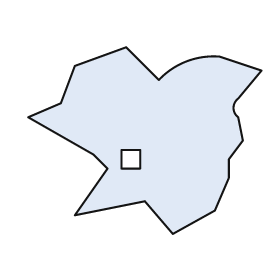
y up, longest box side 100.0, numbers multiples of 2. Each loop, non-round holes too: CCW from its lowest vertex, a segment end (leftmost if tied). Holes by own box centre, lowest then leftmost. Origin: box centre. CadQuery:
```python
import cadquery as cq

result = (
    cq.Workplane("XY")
    .moveTo(12.0, -40.0)
    .lineTo(30.0, -30.0)
    .lineTo(36.0, -16.0)
    .lineTo(36.0, -8.0)
    .lineTo(42.0, 0.0)
    .lineTo(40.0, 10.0)
    .threePointArc((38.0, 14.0), (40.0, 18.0))
    .lineTo(50.0, 30.0)
    .lineTo(32.0, 36.0)
    .threePointArc((18.0, 34.0), (6.0, 26.0))
    .lineTo(-8.0, 40.0)
    .lineTo(-30.0, 32.0)
    .lineTo(-36.0, 16.0)
    .lineTo(-50.0, 10.0)
    .lineTo(-22.0, -6.0)
    .lineTo(-16.0, -12.0)
    .lineTo(-30.0, -32.0)
    .lineTo(0.0, -26.0)
    .close()
    .moveTo(-10.0, -12.0)
    .lineTo(-2.0, -12.0)
    .lineTo(-2.0, -4.0)
    .lineTo(-10.0, -4.0)
    .close()
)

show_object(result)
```